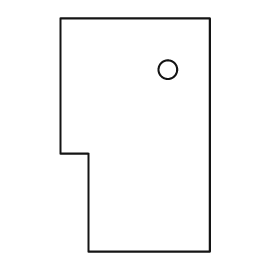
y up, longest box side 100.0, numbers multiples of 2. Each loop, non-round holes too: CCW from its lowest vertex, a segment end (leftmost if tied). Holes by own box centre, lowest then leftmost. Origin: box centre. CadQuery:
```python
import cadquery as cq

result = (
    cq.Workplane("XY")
    .moveTo(-20.0, -50.0)
    .lineTo(32.0, -50.0)
    .lineTo(32.0, 50.0)
    .lineTo(-32.0, 50.0)
    .lineTo(-32.0, -8.0)
    .lineTo(-20.0, -8.0)
    .close()
    .moveTo(14.0, 28.0)
    .circle(4.0)
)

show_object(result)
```